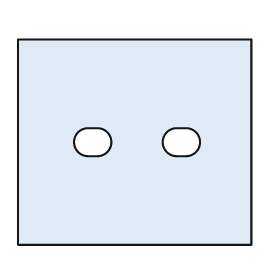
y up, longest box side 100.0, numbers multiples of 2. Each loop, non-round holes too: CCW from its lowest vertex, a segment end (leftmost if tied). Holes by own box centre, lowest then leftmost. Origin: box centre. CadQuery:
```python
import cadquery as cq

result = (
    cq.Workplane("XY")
    .moveTo(-50.0, -44.0)
    .lineTo(50.0, -44.0)
    .lineTo(50.0, 44.0)
    .lineTo(-50.0, 44.0)
    .close()
    .moveTo(-20.0, -6.0)
    .lineTo(-16.0, -6.0)
    .threePointArc((-10.0, 0.0), (-16.0, 6.0))
    .lineTo(-20.0, 6.0)
    .threePointArc((-26.0, 0.0), (-20.0, -6.0))
    .close()
    .moveTo(18.0, -6.0)
    .lineTo(22.0, -6.0)
    .threePointArc((28.0, 0.0), (22.0, 6.0))
    .lineTo(18.0, 6.0)
    .threePointArc((12.0, 0.0), (18.0, -6.0))
    .close()
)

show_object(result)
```